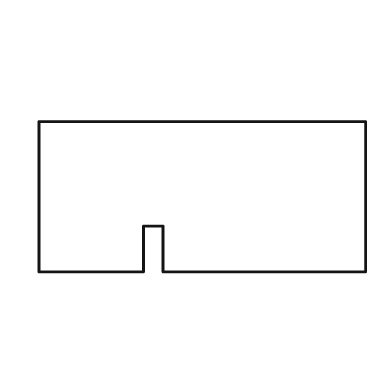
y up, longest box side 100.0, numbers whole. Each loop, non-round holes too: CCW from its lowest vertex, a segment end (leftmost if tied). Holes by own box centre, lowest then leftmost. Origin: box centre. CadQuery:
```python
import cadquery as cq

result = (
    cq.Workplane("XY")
    .moveTo(-50.0, -23.0)
    .lineTo(-18.0, -23.0)
    .lineTo(-18.0, -9.0)
    .lineTo(-12.0, -9.0)
    .lineTo(-12.0, -23.0)
    .lineTo(50.0, -23.0)
    .lineTo(50.0, 23.0)
    .lineTo(-50.0, 23.0)
    .close()
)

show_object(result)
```